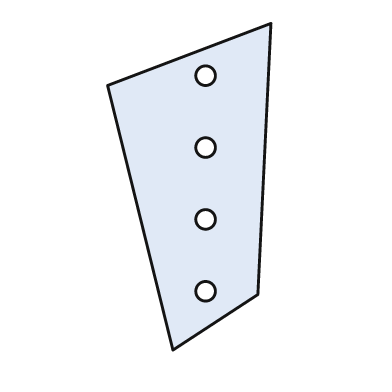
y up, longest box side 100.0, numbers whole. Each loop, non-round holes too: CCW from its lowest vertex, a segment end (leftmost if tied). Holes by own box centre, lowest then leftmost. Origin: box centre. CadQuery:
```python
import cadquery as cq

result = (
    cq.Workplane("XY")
    .moveTo(-5.0, -50.0)
    .lineTo(21.0, -33.0)
    .lineTo(25.0, 50.0)
    .lineTo(-25.0, 31.0)
    .close()
    .moveTo(5.0, -32.0)
    .circle(3.0)
    .moveTo(5.0, -10.0)
    .circle(3.0)
    .moveTo(5.0, 12.0)
    .circle(3.0)
    .moveTo(5.0, 34.0)
    .circle(3.0)
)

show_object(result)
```